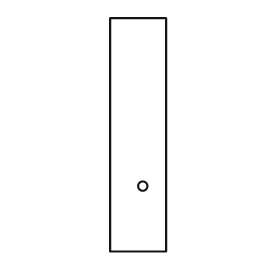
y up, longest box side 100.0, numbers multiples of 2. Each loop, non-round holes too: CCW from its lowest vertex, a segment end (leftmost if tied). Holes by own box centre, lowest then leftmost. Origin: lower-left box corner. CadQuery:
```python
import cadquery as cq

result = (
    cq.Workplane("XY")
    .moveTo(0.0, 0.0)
    .lineTo(24.0, 0.0)
    .lineTo(24.0, 100.0)
    .lineTo(0.0, 100.0)
    .close()
    .moveTo(14.0, 28.0)
    .circle(2.0)
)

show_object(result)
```